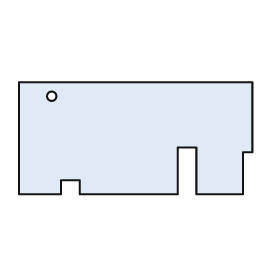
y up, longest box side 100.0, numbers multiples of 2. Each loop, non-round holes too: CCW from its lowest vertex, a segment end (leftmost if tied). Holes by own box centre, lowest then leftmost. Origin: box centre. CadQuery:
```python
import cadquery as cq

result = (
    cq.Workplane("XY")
    .moveTo(-50.0, -24.0)
    .lineTo(-32.0, -24.0)
    .lineTo(-32.0, -18.0)
    .lineTo(-24.0, -18.0)
    .lineTo(-24.0, -24.0)
    .lineTo(18.0, -24.0)
    .lineTo(18.0, -4.0)
    .lineTo(26.0, -4.0)
    .lineTo(26.0, -24.0)
    .lineTo(46.0, -24.0)
    .lineTo(46.0, -6.0)
    .lineTo(50.0, -6.0)
    .lineTo(50.0, 24.0)
    .lineTo(-50.0, 24.0)
    .close()
    .moveTo(-36.0, 18.0)
    .circle(2.0)
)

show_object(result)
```